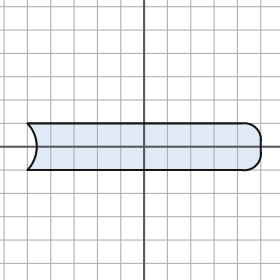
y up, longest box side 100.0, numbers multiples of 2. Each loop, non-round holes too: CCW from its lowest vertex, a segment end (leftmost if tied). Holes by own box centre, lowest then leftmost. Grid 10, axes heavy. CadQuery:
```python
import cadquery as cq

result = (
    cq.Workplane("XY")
    .moveTo(-50.0, -10.0)
    .lineTo(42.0, -10.0)
    .threePointArc((48.0, -8.0), (50.0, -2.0))
    .lineTo(50.0, 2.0)
    .threePointArc((48.0, 8.0), (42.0, 10.0))
    .lineTo(-50.0, 10.0)
    .threePointArc((-46.0, 0.0), (-50.0, -10.0))
    .close()
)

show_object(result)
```